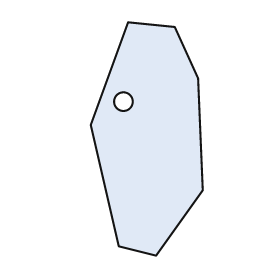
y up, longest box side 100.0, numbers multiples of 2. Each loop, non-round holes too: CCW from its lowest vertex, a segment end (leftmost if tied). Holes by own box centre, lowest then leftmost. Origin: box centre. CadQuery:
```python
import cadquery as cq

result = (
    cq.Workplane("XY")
    .moveTo(4.0, -50.0)
    .lineTo(24.0, -22.0)
    .lineTo(22.0, 26.0)
    .lineTo(12.0, 48.0)
    .lineTo(-8.0, 50.0)
    .lineTo(-24.0, 6.0)
    .lineTo(-12.0, -46.0)
    .close()
    .moveTo(-10.0, 16.0)
    .circle(4.0)
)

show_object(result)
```